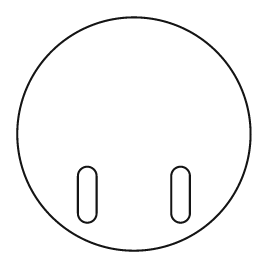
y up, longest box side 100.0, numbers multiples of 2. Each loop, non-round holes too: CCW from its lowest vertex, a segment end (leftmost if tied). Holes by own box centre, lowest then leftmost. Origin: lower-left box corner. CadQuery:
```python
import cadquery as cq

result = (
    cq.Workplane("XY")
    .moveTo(50.0, 50.0)
    .circle(50.0)
    .moveTo(26.0, 16.0)
    .threePointArc((30.0, 12.0), (34.0, 16.0))
    .lineTo(34.0, 32.0)
    .threePointArc((30.0, 36.0), (26.0, 32.0))
    .close()
    .moveTo(66.0, 16.0)
    .threePointArc((70.0, 12.0), (74.0, 16.0))
    .lineTo(74.0, 32.0)
    .threePointArc((70.0, 36.0), (66.0, 32.0))
    .close()
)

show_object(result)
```